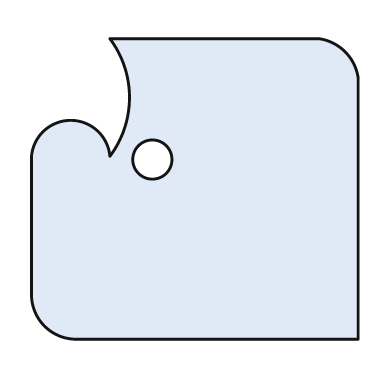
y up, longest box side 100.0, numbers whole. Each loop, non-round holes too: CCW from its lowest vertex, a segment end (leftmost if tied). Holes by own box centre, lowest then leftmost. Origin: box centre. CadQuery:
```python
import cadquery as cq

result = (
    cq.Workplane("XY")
    .moveTo(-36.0, -46.0)
    .lineTo(50.0, -46.0)
    .lineTo(50.0, 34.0)
    .threePointArc((46.0, 42.0), (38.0, 46.0))
    .lineTo(-26.0, 46.0)
    .threePointArc((-20.0, 28.0), (-26.0, 10.0))
    .threePointArc((-38.0, 21.0), (-50.0, 10.0))
    .lineTo(-50.0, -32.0)
    .threePointArc((-46.0, -42.0), (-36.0, -46.0))
    .close()
    .moveTo(-13.0, 9.0)
    .circle(6.0)
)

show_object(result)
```